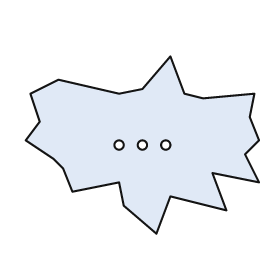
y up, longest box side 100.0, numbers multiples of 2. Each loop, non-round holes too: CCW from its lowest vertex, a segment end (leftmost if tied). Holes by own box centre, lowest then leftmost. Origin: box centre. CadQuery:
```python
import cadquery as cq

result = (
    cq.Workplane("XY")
    .moveTo(6.0, -38.0)
    .lineTo(12.0, -22.0)
    .lineTo(36.0, -28.0)
    .lineTo(30.0, -12.0)
    .lineTo(50.0, -16.0)
    .lineTo(44.0, -4.0)
    .lineTo(50.0, 2.0)
    .lineTo(46.0, 12.0)
    .lineTo(48.0, 22.0)
    .lineTo(26.0, 20.0)
    .lineTo(18.0, 22.0)
    .lineTo(12.0, 38.0)
    .lineTo(0.0, 24.0)
    .lineTo(-10.0, 22.0)
    .lineTo(-36.0, 28.0)
    .lineTo(-48.0, 22.0)
    .lineTo(-44.0, 10.0)
    .lineTo(-50.0, 2.0)
    .lineTo(-38.0, -6.0)
    .lineTo(-34.0, -10.0)
    .lineTo(-30.0, -20.0)
    .lineTo(-10.0, -16.0)
    .lineTo(-8.0, -26.0)
    .close()
    .moveTo(-10.0, 0.0)
    .circle(2.0)
    .moveTo(0.0, 0.0)
    .circle(2.0)
    .moveTo(10.0, 0.0)
    .circle(2.0)
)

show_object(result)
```